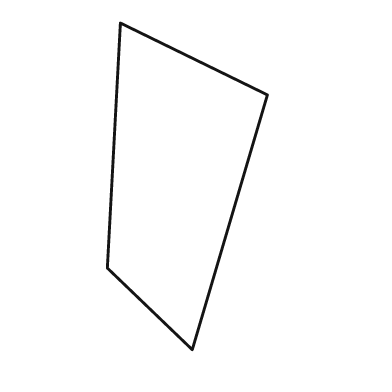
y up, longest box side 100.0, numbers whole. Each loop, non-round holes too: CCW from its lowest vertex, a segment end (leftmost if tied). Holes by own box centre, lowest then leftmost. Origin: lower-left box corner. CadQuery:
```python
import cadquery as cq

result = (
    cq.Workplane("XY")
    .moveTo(26.0, 0.0)
    .lineTo(49.0, 78.0)
    .lineTo(4.0, 100.0)
    .lineTo(0.0, 25.0)
    .close()
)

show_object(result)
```